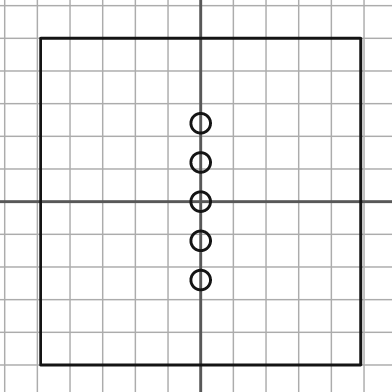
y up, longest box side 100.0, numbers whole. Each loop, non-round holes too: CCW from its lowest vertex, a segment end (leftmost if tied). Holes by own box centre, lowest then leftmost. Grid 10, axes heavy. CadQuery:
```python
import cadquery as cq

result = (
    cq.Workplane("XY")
    .moveTo(-49.0, -50.0)
    .lineTo(49.0, -50.0)
    .lineTo(49.0, 50.0)
    .lineTo(-49.0, 50.0)
    .close()
    .moveTo(0.0, -24.0)
    .circle(3.0)
    .moveTo(0.0, -12.0)
    .circle(3.0)
    .moveTo(0.0, 0.0)
    .circle(3.0)
    .moveTo(0.0, 12.0)
    .circle(3.0)
    .moveTo(0.0, 24.0)
    .circle(3.0)
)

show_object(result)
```